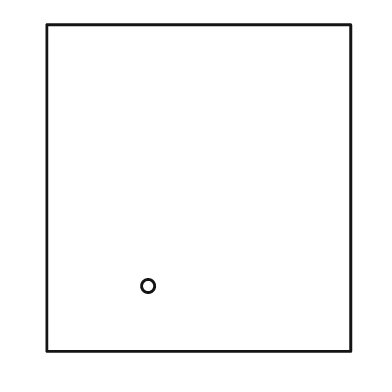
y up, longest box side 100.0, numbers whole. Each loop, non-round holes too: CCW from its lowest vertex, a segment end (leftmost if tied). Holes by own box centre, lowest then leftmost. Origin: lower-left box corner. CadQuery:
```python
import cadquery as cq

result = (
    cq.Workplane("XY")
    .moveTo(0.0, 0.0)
    .lineTo(93.0, 0.0)
    .lineTo(93.0, 100.0)
    .lineTo(0.0, 100.0)
    .close()
    .moveTo(31.0, 20.0)
    .circle(2.0)
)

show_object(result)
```